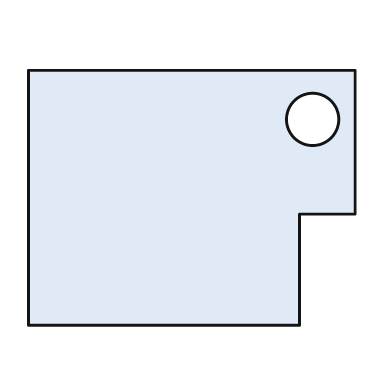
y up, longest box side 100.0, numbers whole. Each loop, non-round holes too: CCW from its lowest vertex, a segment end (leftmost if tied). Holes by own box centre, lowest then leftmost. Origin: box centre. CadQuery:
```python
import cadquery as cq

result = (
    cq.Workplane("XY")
    .moveTo(-50.0, -39.0)
    .lineTo(33.0, -39.0)
    .lineTo(33.0, -5.0)
    .lineTo(50.0, -5.0)
    .lineTo(50.0, 39.0)
    .lineTo(-50.0, 39.0)
    .close()
    .moveTo(37.0, 24.0)
    .circle(8.0)
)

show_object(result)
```